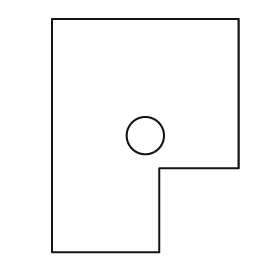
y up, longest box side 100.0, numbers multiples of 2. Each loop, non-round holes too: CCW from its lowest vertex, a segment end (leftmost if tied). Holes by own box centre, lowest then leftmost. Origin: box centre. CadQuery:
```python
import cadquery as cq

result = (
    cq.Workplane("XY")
    .moveTo(-40.0, -50.0)
    .lineTo(6.0, -50.0)
    .lineTo(6.0, -14.0)
    .lineTo(40.0, -14.0)
    .lineTo(40.0, 50.0)
    .lineTo(-40.0, 50.0)
    .close()
    .moveTo(0.0, 0.0)
    .circle(8.0)
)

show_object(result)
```